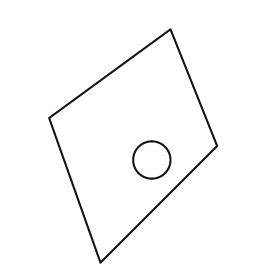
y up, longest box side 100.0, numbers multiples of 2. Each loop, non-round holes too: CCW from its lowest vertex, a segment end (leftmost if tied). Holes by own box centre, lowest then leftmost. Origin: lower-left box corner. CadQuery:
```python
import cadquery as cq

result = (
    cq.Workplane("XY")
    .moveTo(22.0, 0.0)
    .lineTo(72.0, 50.0)
    .lineTo(52.0, 100.0)
    .lineTo(0.0, 62.0)
    .close()
    .moveTo(44.0, 44.0)
    .circle(8.0)
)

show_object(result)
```